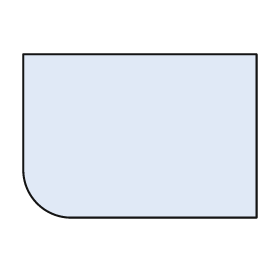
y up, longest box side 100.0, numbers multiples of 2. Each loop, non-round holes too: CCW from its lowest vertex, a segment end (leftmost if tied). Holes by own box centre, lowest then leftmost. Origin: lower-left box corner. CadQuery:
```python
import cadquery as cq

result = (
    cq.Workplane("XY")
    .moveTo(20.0, 0.0)
    .lineTo(100.0, 0.0)
    .lineTo(100.0, 70.0)
    .lineTo(0.0, 70.0)
    .lineTo(0.0, 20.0)
    .threePointArc((6.0, 6.0), (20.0, 0.0))
    .close()
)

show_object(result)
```